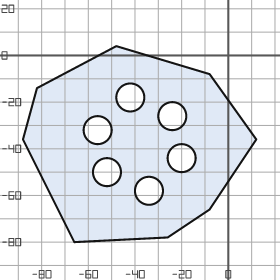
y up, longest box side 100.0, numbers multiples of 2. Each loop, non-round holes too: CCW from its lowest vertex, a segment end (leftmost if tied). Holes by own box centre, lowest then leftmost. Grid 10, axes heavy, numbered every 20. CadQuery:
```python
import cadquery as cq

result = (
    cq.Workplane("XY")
    .moveTo(-66.0, -80.0)
    .lineTo(-26.0, -78.0)
    .lineTo(-8.0, -66.0)
    .lineTo(12.0, -36.0)
    .lineTo(-8.0, -8.0)
    .lineTo(-48.0, 4.0)
    .lineTo(-82.0, -14.0)
    .lineTo(-88.0, -36.0)
    .close()
    .moveTo(-34.0, -58.0)
    .circle(6.0)
    .moveTo(-52.0, -50.0)
    .circle(6.0)
    .moveTo(-20.0, -44.0)
    .circle(6.0)
    .moveTo(-56.0, -32.0)
    .circle(6.0)
    .moveTo(-24.0, -26.0)
    .circle(6.0)
    .moveTo(-42.0, -18.0)
    .circle(6.0)
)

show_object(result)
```